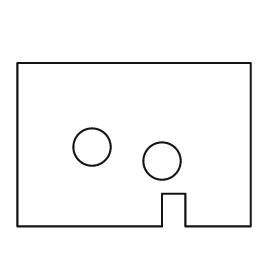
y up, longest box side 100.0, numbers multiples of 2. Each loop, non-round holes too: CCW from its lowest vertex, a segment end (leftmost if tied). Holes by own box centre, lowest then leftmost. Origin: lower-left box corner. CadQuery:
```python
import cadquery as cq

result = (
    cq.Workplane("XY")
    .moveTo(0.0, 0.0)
    .lineTo(62.0, 0.0)
    .lineTo(62.0, 14.0)
    .lineTo(72.0, 14.0)
    .lineTo(72.0, 0.0)
    .lineTo(100.0, 0.0)
    .lineTo(100.0, 70.0)
    .lineTo(0.0, 70.0)
    .close()
    .moveTo(62.0, 28.0)
    .circle(8.0)
    .moveTo(32.0, 34.0)
    .circle(8.0)
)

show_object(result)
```